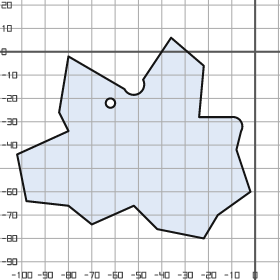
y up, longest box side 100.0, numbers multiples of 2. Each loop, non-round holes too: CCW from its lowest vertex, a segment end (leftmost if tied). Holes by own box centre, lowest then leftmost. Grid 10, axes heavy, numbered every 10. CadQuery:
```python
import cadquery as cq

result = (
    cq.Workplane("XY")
    .moveTo(-22.0, -80.0)
    .lineTo(-16.0, -70.0)
    .lineTo(-2.0, -60.0)
    .lineTo(-8.0, -42.0)
    .lineTo(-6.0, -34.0)
    .threePointArc((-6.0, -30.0), (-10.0, -28.0))
    .lineTo(-24.0, -28.0)
    .lineTo(-22.0, -6.0)
    .lineTo(-36.0, 6.0)
    .lineTo(-48.0, -12.0)
    .threePointArc((-50.0, -18.0), (-56.0, -16.0))
    .lineTo(-80.0, -2.0)
    .lineTo(-84.0, -26.0)
    .lineTo(-80.0, -34.0)
    .lineTo(-102.0, -44.0)
    .lineTo(-98.0, -64.0)
    .lineTo(-80.0, -66.0)
    .lineTo(-70.0, -74.0)
    .lineTo(-52.0, -66.0)
    .lineTo(-42.0, -76.0)
    .close()
    .moveTo(-62.0, -22.0)
    .circle(2.0)
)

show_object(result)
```